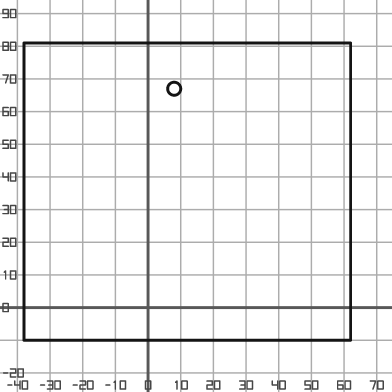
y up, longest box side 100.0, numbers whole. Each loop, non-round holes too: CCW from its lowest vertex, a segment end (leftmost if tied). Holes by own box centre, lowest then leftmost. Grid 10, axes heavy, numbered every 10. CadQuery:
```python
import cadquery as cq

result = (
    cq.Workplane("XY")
    .moveTo(-38.0, -10.0)
    .lineTo(62.0, -10.0)
    .lineTo(62.0, 81.0)
    .lineTo(-38.0, 81.0)
    .close()
    .moveTo(8.0, 67.0)
    .circle(2.0)
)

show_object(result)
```